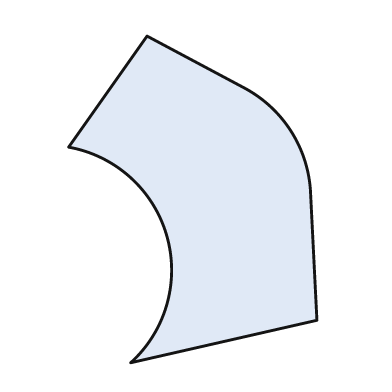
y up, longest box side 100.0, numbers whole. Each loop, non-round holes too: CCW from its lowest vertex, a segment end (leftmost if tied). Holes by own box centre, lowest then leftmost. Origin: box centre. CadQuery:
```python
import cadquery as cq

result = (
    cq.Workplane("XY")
    .moveTo(-19.0, -50.0)
    .lineTo(38.0, -37.0)
    .lineTo(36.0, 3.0)
    .threePointArc((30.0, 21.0), (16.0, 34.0))
    .lineTo(-14.0, 50.0)
    .lineTo(-38.0, 16.0)
    .threePointArc((-8.0, -11.0), (-19.0, -50.0))
    .close()
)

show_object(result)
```